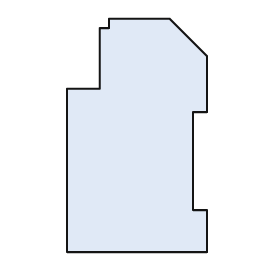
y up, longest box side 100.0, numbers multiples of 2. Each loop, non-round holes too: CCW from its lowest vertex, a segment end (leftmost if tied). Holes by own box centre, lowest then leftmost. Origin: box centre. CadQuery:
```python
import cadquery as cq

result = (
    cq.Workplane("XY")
    .moveTo(-30.0, -50.0)
    .lineTo(30.0, -50.0)
    .lineTo(30.0, -32.0)
    .lineTo(24.0, -32.0)
    .lineTo(24.0, 10.0)
    .lineTo(30.0, 10.0)
    .lineTo(30.0, 34.0)
    .lineTo(14.0, 50.0)
    .lineTo(-12.0, 50.0)
    .lineTo(-12.0, 46.0)
    .lineTo(-16.0, 46.0)
    .lineTo(-16.0, 20.0)
    .lineTo(-30.0, 20.0)
    .close()
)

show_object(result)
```